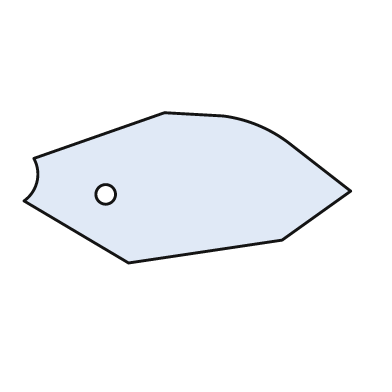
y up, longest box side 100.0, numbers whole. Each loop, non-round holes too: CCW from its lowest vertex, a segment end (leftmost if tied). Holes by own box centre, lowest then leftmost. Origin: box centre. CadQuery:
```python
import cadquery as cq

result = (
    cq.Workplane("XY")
    .moveTo(-18.0, -23.0)
    .lineTo(29.0, -16.0)
    .lineTo(50.0, -1.0)
    .lineTo(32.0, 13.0)
    .threePointArc((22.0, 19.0), (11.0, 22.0))
    .lineTo(-7.0, 23.0)
    .lineTo(-47.0, 9.0)
    .threePointArc((-46.0, 2.0), (-50.0, -4.0))
    .close()
    .moveTo(-25.0, -2.0)
    .circle(3.0)
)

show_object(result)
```